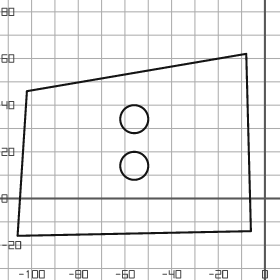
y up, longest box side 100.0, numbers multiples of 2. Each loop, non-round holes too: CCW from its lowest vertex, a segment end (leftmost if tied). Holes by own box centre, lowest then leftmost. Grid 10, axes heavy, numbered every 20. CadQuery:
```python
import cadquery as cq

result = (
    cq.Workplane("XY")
    .moveTo(-106.0, -16.0)
    .lineTo(-6.0, -14.0)
    .lineTo(-8.0, 62.0)
    .lineTo(-102.0, 46.0)
    .close()
    .moveTo(-56.0, 14.0)
    .circle(6.0)
    .moveTo(-56.0, 34.0)
    .circle(6.0)
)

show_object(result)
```